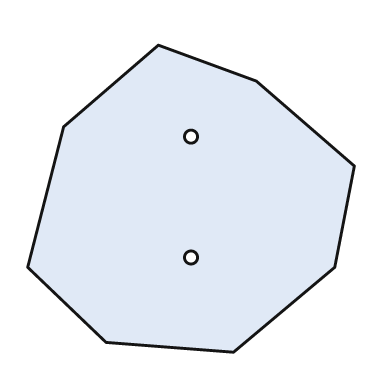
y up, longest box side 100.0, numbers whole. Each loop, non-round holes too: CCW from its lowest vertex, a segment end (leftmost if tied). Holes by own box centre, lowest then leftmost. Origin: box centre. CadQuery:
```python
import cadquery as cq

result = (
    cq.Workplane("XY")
    .moveTo(13.0, -47.0)
    .lineTo(44.0, -21.0)
    .lineTo(50.0, 10.0)
    .lineTo(20.0, 36.0)
    .lineTo(-10.0, 47.0)
    .lineTo(-39.0, 22.0)
    .lineTo(-50.0, -21.0)
    .lineTo(-26.0, -44.0)
    .close()
    .moveTo(0.0, -18.0)
    .circle(2.0)
    .moveTo(0.0, 19.0)
    .circle(2.0)
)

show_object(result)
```